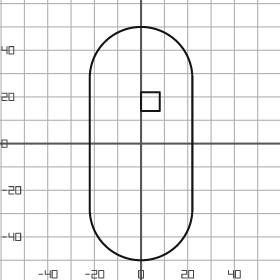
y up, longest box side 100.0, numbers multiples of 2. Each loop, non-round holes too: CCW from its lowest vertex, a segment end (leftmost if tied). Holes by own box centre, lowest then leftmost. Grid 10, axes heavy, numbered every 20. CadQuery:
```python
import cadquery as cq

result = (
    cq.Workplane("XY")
    .moveTo(-22.0, -28.0)
    .threePointArc((0.0, -50.0), (22.0, -28.0))
    .lineTo(22.0, 28.0)
    .threePointArc((0.0, 50.0), (-22.0, 28.0))
    .close()
    .moveTo(0.0, 14.0)
    .lineTo(8.0, 14.0)
    .lineTo(8.0, 22.0)
    .lineTo(0.0, 22.0)
    .close()
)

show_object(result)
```